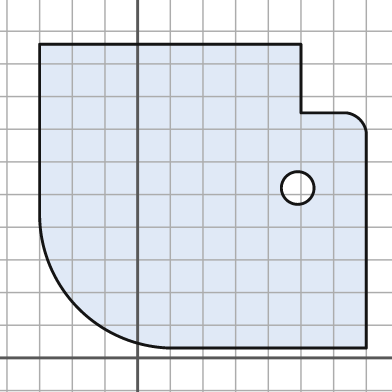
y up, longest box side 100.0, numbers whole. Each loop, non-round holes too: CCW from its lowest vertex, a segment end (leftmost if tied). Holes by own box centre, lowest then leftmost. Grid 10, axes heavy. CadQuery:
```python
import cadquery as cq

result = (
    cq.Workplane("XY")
    .moveTo(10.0, 3.0)
    .lineTo(70.0, 3.0)
    .lineTo(70.0, 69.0)
    .threePointArc((68.0, 73.0), (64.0, 75.0))
    .lineTo(50.0, 75.0)
    .lineTo(50.0, 96.0)
    .lineTo(-30.0, 96.0)
    .lineTo(-30.0, 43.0)
    .threePointArc((-18.0, 15.0), (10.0, 3.0))
    .close()
    .moveTo(49.0, 52.0)
    .circle(5.0)
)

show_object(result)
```